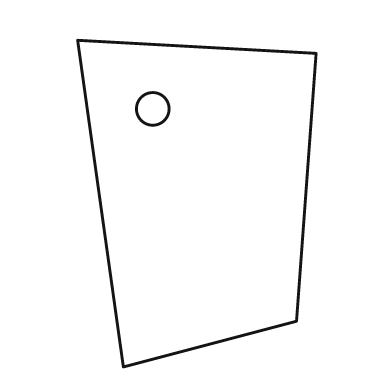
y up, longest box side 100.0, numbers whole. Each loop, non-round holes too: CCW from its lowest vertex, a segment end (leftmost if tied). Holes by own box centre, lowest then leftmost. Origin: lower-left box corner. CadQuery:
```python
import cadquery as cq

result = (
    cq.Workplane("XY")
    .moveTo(14.0, 0.0)
    .lineTo(67.0, 14.0)
    .lineTo(73.0, 96.0)
    .lineTo(0.0, 100.0)
    .close()
    .moveTo(23.0, 79.0)
    .circle(5.0)
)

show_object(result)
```